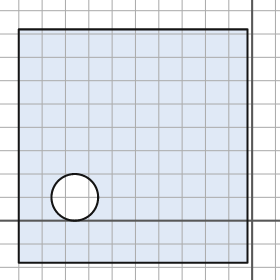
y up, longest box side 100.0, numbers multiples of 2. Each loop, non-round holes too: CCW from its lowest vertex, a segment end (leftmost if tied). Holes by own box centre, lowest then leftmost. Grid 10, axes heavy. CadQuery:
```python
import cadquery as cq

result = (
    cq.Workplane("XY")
    .moveTo(-100.0, -18.0)
    .lineTo(-2.0, -18.0)
    .lineTo(-2.0, 82.0)
    .lineTo(-100.0, 82.0)
    .close()
    .moveTo(-76.0, 10.0)
    .circle(10.0)
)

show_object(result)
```